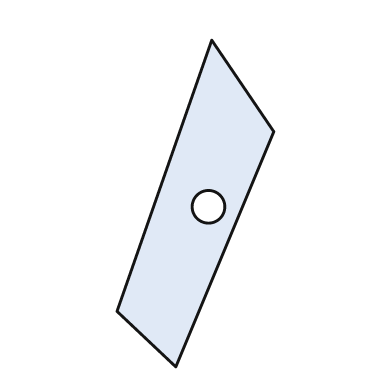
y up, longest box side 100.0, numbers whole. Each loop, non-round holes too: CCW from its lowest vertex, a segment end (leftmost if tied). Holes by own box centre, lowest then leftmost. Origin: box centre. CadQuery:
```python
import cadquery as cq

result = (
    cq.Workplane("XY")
    .moveTo(-6.0, -50.0)
    .lineTo(24.0, 22.0)
    .lineTo(5.0, 50.0)
    .lineTo(-24.0, -33.0)
    .close()
    .moveTo(4.0, -1.0)
    .circle(5.0)
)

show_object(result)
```